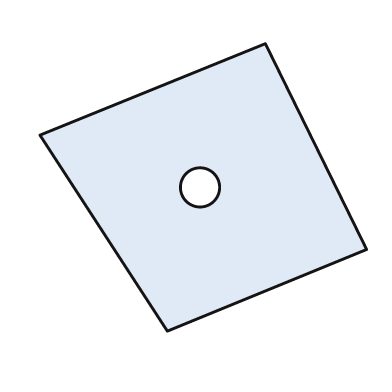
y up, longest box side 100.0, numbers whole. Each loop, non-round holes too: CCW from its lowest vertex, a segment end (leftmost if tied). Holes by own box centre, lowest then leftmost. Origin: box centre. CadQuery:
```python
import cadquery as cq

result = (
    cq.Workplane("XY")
    .moveTo(-11.0, -44.0)
    .lineTo(50.0, -19.0)
    .lineTo(19.0, 44.0)
    .lineTo(-50.0, 16.0)
    .close()
    .moveTo(-1.0, 0.0)
    .circle(6.0)
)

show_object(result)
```